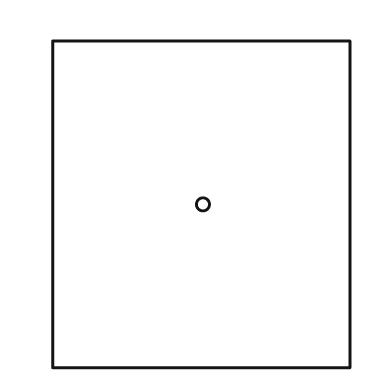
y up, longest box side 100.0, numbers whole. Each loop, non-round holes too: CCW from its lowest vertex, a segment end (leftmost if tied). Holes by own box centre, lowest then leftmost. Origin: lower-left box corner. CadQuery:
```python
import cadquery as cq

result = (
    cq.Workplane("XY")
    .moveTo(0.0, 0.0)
    .lineTo(91.0, 0.0)
    .lineTo(91.0, 100.0)
    .lineTo(0.0, 100.0)
    .close()
    .moveTo(46.0, 50.0)
    .circle(2.0)
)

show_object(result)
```